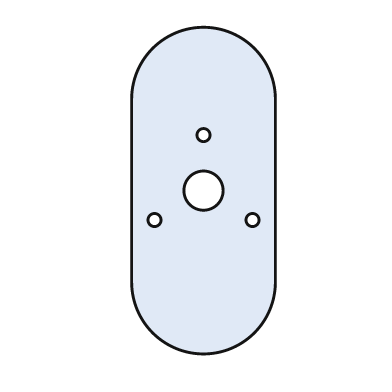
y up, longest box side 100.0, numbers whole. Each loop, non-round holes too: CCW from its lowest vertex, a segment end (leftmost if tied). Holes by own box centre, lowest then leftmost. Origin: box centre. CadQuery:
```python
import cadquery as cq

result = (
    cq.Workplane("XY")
    .moveTo(-22.0, -28.0)
    .threePointArc((0.0, -50.0), (22.0, -28.0))
    .lineTo(22.0, 28.0)
    .threePointArc((0.0, 50.0), (-22.0, 28.0))
    .close()
    .moveTo(-15.0, -9.0)
    .circle(2.0)
    .moveTo(15.0, -9.0)
    .circle(2.0)
    .moveTo(0.0, 0.0)
    .circle(6.0)
    .moveTo(0.0, 17.0)
    .circle(2.0)
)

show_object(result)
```